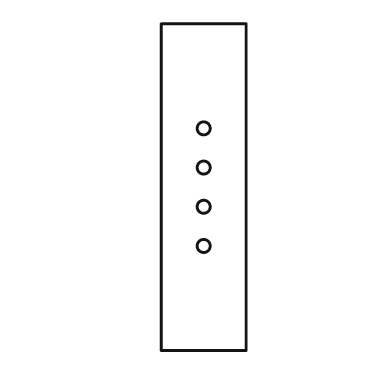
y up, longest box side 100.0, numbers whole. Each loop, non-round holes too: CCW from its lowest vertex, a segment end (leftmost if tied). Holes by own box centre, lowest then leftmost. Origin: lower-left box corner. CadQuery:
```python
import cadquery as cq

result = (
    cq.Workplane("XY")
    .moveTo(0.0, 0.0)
    .lineTo(26.0, 0.0)
    .lineTo(26.0, 100.0)
    .lineTo(0.0, 100.0)
    .close()
    .moveTo(13.0, 32.0)
    .circle(2.0)
    .moveTo(13.0, 44.0)
    .circle(2.0)
    .moveTo(13.0, 56.0)
    .circle(2.0)
    .moveTo(13.0, 68.0)
    .circle(2.0)
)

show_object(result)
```